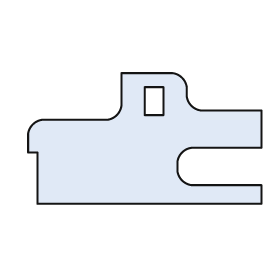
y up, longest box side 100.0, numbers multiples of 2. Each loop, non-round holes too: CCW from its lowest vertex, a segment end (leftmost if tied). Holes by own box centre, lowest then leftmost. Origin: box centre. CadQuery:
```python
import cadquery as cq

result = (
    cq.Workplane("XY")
    .moveTo(-46.0, -28.0)
    .lineTo(50.0, -28.0)
    .lineTo(50.0, -20.0)
    .lineTo(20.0, -20.0)
    .threePointArc((16.0, -18.0), (14.0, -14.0))
    .lineTo(14.0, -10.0)
    .threePointArc((16.0, -6.0), (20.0, -4.0))
    .lineTo(50.0, -4.0)
    .lineTo(50.0, 12.0)
    .lineTo(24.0, 12.0)
    .threePointArc((20.0, 14.0), (18.0, 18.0))
    .lineTo(18.0, 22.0)
    .threePointArc((16.0, 26.0), (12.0, 28.0))
    .lineTo(-10.0, 28.0)
    .lineTo(-10.0, 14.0)
    .threePointArc((-12.0, 10.0), (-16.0, 8.0))
    .lineTo(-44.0, 8.0)
    .threePointArc((-48.0, 6.0), (-50.0, 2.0))
    .lineTo(-50.0, -6.0)
    .lineTo(-46.0, -6.0)
    .close()
    .moveTo(0.0, 10.0)
    .lineTo(8.0, 10.0)
    .lineTo(8.0, 22.0)
    .lineTo(0.0, 22.0)
    .close()
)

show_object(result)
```